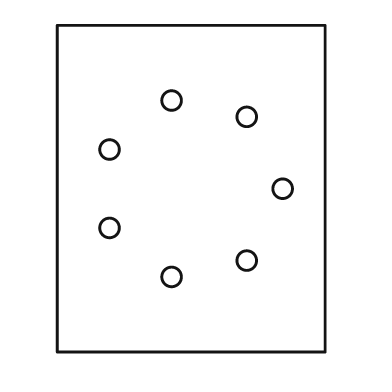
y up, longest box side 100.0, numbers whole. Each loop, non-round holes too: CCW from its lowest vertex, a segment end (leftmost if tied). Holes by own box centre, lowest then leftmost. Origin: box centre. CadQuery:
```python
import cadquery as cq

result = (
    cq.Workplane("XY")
    .moveTo(-41.0, -50.0)
    .lineTo(41.0, -50.0)
    .lineTo(41.0, 50.0)
    .lineTo(-41.0, 50.0)
    .close()
    .moveTo(-6.0, -27.0)
    .circle(3.0)
    .moveTo(17.0, -22.0)
    .circle(3.0)
    .moveTo(-25.0, -12.0)
    .circle(3.0)
    .moveTo(28.0, 0.0)
    .circle(3.0)
    .moveTo(-25.0, 12.0)
    .circle(3.0)
    .moveTo(17.0, 22.0)
    .circle(3.0)
    .moveTo(-6.0, 27.0)
    .circle(3.0)
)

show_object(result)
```